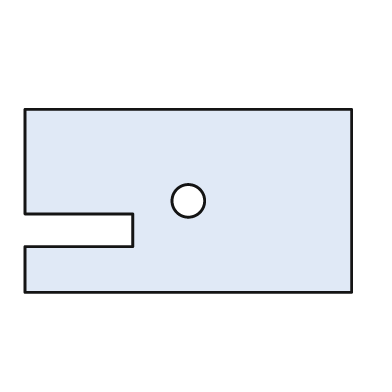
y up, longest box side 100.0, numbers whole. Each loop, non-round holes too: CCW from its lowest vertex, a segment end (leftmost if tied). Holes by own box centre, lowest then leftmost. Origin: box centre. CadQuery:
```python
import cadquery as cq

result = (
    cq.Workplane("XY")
    .moveTo(-50.0, -28.0)
    .lineTo(50.0, -28.0)
    .lineTo(50.0, 28.0)
    .lineTo(-50.0, 28.0)
    .lineTo(-50.0, -4.0)
    .lineTo(-17.0, -4.0)
    .lineTo(-17.0, -14.0)
    .lineTo(-50.0, -14.0)
    .close()
    .moveTo(0.0, 0.0)
    .circle(5.0)
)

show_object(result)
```